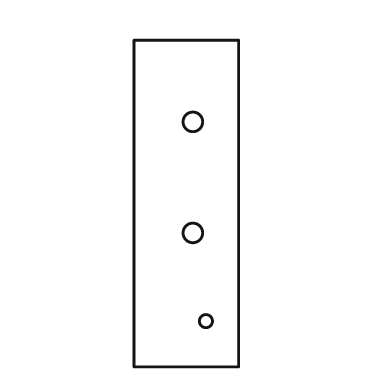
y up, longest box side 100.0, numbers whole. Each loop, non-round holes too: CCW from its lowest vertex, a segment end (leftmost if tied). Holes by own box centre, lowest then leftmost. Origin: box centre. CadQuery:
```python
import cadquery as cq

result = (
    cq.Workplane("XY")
    .moveTo(-16.0, -50.0)
    .lineTo(16.0, -50.0)
    .lineTo(16.0, 50.0)
    .lineTo(-16.0, 50.0)
    .close()
    .moveTo(6.0, -36.0)
    .circle(2.0)
    .moveTo(2.0, -9.0)
    .circle(3.0)
    .moveTo(2.0, 25.0)
    .circle(3.0)
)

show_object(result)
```